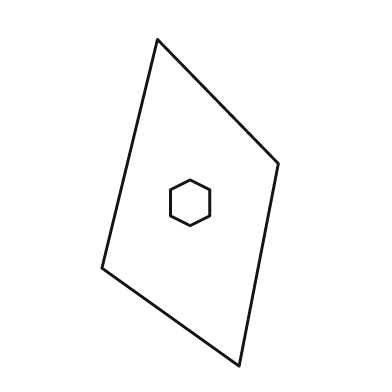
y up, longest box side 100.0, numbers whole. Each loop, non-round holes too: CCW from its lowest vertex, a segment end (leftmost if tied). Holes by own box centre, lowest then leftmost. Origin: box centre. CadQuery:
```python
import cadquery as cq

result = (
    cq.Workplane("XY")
    .moveTo(15.0, -50.0)
    .lineTo(27.0, 12.0)
    .lineTo(-10.0, 50.0)
    .lineTo(-27.0, -20.0)
    .close()
    .moveTo(0.0, -7.0)
    .lineTo(6.0, -4.0)
    .lineTo(6.0, 4.0)
    .lineTo(0.0, 7.0)
    .lineTo(-6.0, 4.0)
    .lineTo(-6.0, -4.0)
    .close()
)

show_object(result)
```